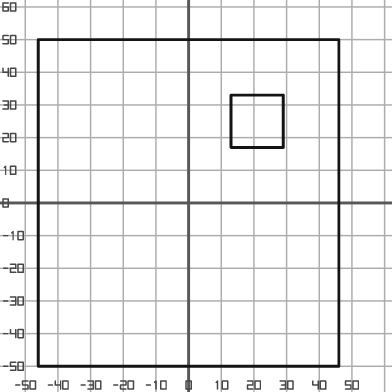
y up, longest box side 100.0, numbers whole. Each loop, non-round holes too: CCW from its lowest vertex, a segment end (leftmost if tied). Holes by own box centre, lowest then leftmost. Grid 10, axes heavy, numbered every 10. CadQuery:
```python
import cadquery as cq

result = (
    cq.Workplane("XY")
    .moveTo(-46.0, -50.0)
    .lineTo(46.0, -50.0)
    .lineTo(46.0, 50.0)
    .lineTo(-46.0, 50.0)
    .close()
    .moveTo(13.0, 17.0)
    .lineTo(29.0, 17.0)
    .lineTo(29.0, 33.0)
    .lineTo(13.0, 33.0)
    .close()
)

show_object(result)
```